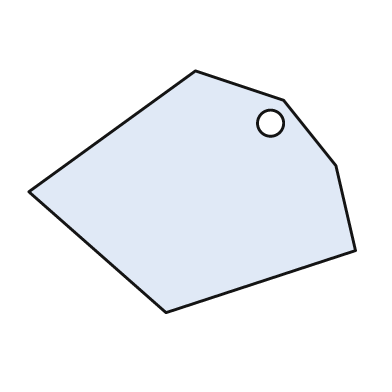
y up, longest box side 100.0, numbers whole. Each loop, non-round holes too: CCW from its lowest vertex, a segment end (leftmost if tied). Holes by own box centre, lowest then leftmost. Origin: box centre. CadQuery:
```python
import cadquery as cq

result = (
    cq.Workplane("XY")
    .moveTo(-8.0, -37.0)
    .lineTo(50.0, -18.0)
    .lineTo(44.0, 8.0)
    .lineTo(28.0, 28.0)
    .lineTo(1.0, 37.0)
    .lineTo(-50.0, 0.0)
    .close()
    .moveTo(24.0, 21.0)
    .circle(4.0)
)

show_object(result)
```